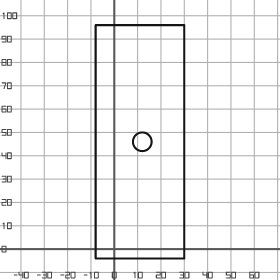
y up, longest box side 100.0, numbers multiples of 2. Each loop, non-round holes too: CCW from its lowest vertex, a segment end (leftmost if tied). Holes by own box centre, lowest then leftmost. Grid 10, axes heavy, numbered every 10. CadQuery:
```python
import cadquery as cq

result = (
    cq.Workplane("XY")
    .moveTo(-8.0, -4.0)
    .lineTo(30.0, -4.0)
    .lineTo(30.0, 96.0)
    .lineTo(-8.0, 96.0)
    .close()
    .moveTo(12.0, 46.0)
    .circle(4.0)
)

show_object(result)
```